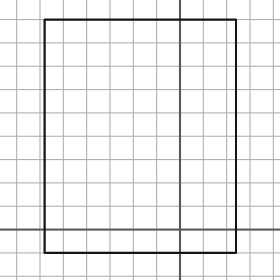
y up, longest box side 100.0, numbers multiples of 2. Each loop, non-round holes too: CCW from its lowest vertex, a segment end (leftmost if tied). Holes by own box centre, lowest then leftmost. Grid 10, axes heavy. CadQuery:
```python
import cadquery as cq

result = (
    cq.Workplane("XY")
    .moveTo(-58.0, -10.0)
    .lineTo(24.0, -10.0)
    .lineTo(24.0, 90.0)
    .lineTo(-58.0, 90.0)
    .close()
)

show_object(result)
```